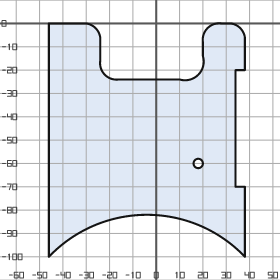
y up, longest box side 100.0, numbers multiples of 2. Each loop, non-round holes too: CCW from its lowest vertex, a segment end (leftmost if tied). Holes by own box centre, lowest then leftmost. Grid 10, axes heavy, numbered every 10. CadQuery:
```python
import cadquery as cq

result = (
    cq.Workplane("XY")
    .moveTo(-46.0, -100.0)
    .threePointArc((-4.0, -82.0), (38.0, -100.0))
    .lineTo(38.0, -70.0)
    .lineTo(34.0, -70.0)
    .lineTo(34.0, -20.0)
    .lineTo(38.0, -20.0)
    .lineTo(38.0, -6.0)
    .threePointArc((36.0, -2.0), (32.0, 0.0))
    .lineTo(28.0, 0.0)
    .threePointArc((22.0, -2.0), (20.0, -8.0))
    .lineTo(20.0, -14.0)
    .threePointArc((18.0, -22.0), (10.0, -24.0))
    .lineTo(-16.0, -24.0)
    .threePointArc((-22.0, -22.0), (-24.0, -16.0))
    .lineTo(-24.0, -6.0)
    .threePointArc((-26.0, -2.0), (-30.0, 0.0))
    .lineTo(-46.0, 0.0)
    .close()
    .moveTo(18.0, -60.0)
    .circle(2.0)
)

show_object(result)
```